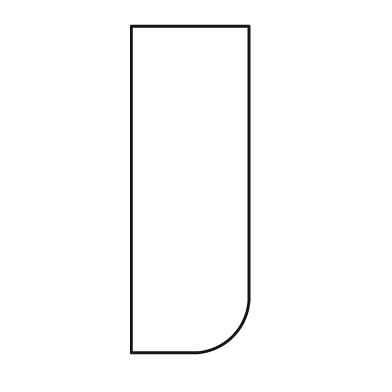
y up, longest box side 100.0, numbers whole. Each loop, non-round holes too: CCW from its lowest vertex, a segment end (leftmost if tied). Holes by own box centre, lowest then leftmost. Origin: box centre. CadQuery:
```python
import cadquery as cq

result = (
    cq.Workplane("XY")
    .moveTo(-18.0, -50.0)
    .lineTo(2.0, -50.0)
    .threePointArc((13.0, -45.0), (18.0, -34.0))
    .lineTo(18.0, 50.0)
    .lineTo(-18.0, 50.0)
    .close()
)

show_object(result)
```